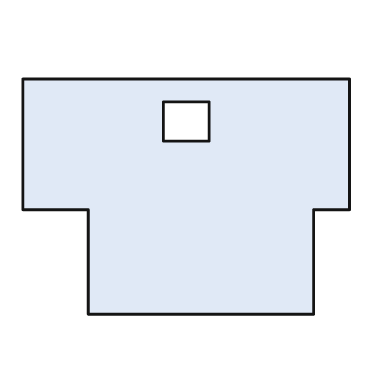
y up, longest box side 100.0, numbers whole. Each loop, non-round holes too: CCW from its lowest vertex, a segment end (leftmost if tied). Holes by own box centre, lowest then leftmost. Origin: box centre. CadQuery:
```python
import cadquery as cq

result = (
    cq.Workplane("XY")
    .moveTo(-30.0, -36.0)
    .lineTo(39.0, -36.0)
    .lineTo(39.0, -4.0)
    .lineTo(50.0, -4.0)
    .lineTo(50.0, 36.0)
    .lineTo(-50.0, 36.0)
    .lineTo(-50.0, -4.0)
    .lineTo(-30.0, -4.0)
    .close()
    .moveTo(-7.0, 17.0)
    .lineTo(7.0, 17.0)
    .lineTo(7.0, 29.0)
    .lineTo(-7.0, 29.0)
    .close()
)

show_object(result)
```